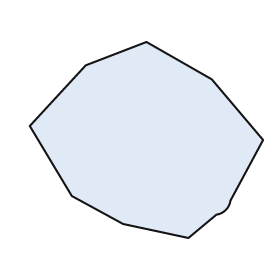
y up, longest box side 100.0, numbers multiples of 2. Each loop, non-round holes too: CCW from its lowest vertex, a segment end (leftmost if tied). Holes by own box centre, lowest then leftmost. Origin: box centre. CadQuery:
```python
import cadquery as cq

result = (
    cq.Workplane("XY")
    .moveTo(18.0, -42.0)
    .lineTo(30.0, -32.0)
    .threePointArc((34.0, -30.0), (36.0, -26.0))
    .lineTo(50.0, 0.0)
    .lineTo(28.0, 26.0)
    .lineTo(0.0, 42.0)
    .lineTo(-26.0, 32.0)
    .lineTo(-50.0, 6.0)
    .lineTo(-32.0, -24.0)
    .lineTo(-10.0, -36.0)
    .close()
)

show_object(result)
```